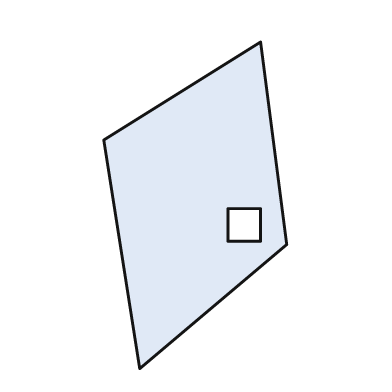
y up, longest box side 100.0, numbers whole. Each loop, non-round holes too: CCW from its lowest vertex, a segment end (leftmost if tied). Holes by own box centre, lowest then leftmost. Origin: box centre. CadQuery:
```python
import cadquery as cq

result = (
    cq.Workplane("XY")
    .moveTo(-17.0, -50.0)
    .lineTo(28.0, -12.0)
    .lineTo(20.0, 50.0)
    .lineTo(-28.0, 20.0)
    .close()
    .moveTo(10.0, -11.0)
    .lineTo(20.0, -11.0)
    .lineTo(20.0, -1.0)
    .lineTo(10.0, -1.0)
    .close()
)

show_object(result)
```